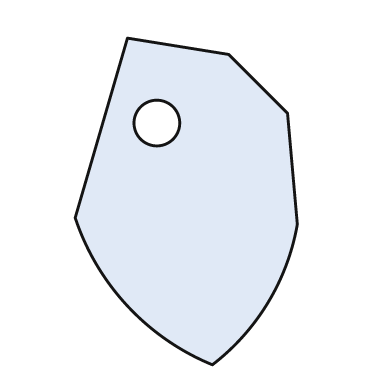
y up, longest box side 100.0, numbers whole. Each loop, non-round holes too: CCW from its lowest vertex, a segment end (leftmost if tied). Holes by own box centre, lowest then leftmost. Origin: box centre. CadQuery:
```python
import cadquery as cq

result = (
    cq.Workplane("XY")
    .moveTo(8.0, -50.0)
    .threePointArc((25.0, -31.0), (34.0, -7.0))
    .lineTo(31.0, 27.0)
    .lineTo(13.0, 45.0)
    .lineTo(-18.0, 50.0)
    .lineTo(-34.0, -5.0)
    .threePointArc((-18.0, -32.0), (8.0, -50.0))
    .close()
    .moveTo(-9.0, 24.0)
    .circle(7.0)
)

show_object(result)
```